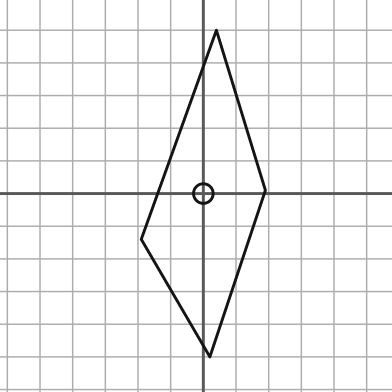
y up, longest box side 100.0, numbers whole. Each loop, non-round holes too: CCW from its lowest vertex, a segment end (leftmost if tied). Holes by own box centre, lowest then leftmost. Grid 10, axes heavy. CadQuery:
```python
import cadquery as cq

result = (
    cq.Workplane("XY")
    .moveTo(2.0, -50.0)
    .lineTo(19.0, 1.0)
    .lineTo(4.0, 50.0)
    .lineTo(-19.0, -14.0)
    .close()
    .moveTo(0.0, 0.0)
    .circle(3.0)
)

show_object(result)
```